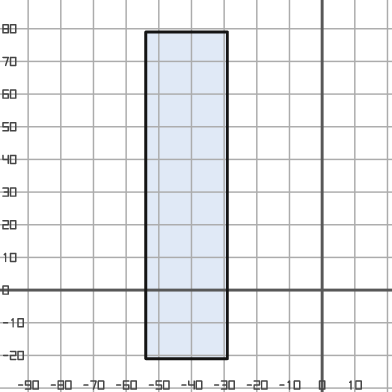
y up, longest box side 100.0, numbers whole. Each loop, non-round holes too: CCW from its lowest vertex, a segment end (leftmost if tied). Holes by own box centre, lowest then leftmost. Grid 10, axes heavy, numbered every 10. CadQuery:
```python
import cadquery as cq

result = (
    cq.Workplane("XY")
    .moveTo(-54.0, -21.0)
    .lineTo(-29.0, -21.0)
    .lineTo(-29.0, 79.0)
    .lineTo(-54.0, 79.0)
    .close()
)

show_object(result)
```